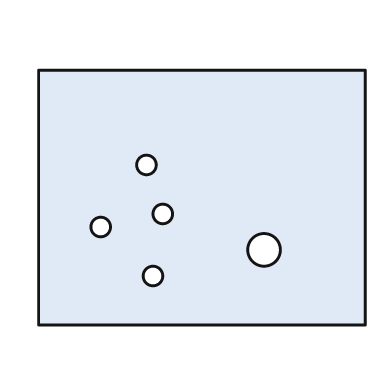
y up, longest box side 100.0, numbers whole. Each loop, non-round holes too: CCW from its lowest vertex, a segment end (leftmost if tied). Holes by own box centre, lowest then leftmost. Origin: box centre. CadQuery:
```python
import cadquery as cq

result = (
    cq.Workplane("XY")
    .moveTo(-50.0, -39.0)
    .lineTo(50.0, -39.0)
    .lineTo(50.0, 39.0)
    .lineTo(-50.0, 39.0)
    .close()
    .moveTo(-15.0, -24.0)
    .circle(3.0)
    .moveTo(19.0, -16.0)
    .circle(5.0)
    .moveTo(-31.0, -9.0)
    .circle(3.0)
    .moveTo(-12.0, -5.0)
    .circle(3.0)
    .moveTo(-17.0, 10.0)
    .circle(3.0)
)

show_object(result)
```